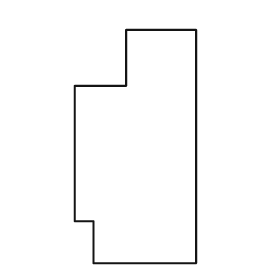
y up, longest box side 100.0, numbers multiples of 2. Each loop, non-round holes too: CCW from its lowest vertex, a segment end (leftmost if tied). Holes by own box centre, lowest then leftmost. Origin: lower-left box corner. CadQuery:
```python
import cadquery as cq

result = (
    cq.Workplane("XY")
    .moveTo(8.0, 0.0)
    .lineTo(52.0, 0.0)
    .lineTo(52.0, 100.0)
    .lineTo(22.0, 100.0)
    .lineTo(22.0, 76.0)
    .lineTo(0.0, 76.0)
    .lineTo(0.0, 18.0)
    .lineTo(8.0, 18.0)
    .close()
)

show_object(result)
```